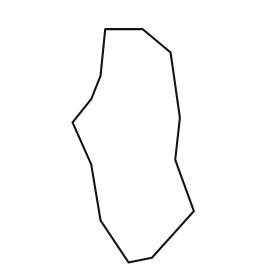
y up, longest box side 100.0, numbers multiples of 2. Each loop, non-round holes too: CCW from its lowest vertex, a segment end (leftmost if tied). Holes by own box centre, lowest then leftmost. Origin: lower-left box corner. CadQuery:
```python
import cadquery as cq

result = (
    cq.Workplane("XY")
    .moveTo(24.0, 0.0)
    .lineTo(34.0, 2.0)
    .lineTo(52.0, 22.0)
    .lineTo(44.0, 44.0)
    .lineTo(46.0, 62.0)
    .lineTo(42.0, 90.0)
    .lineTo(30.0, 100.0)
    .lineTo(14.0, 100.0)
    .lineTo(12.0, 80.0)
    .lineTo(8.0, 70.0)
    .lineTo(0.0, 60.0)
    .lineTo(8.0, 42.0)
    .lineTo(12.0, 18.0)
    .close()
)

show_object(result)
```